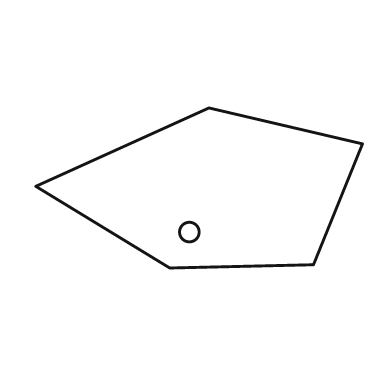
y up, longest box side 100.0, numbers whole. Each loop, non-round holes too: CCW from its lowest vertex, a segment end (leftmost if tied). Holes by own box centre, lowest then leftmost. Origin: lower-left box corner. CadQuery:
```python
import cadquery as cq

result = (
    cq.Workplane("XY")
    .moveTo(41.0, 0.0)
    .lineTo(85.0, 1.0)
    .lineTo(100.0, 38.0)
    .lineTo(53.0, 49.0)
    .lineTo(0.0, 25.0)
    .close()
    .moveTo(47.0, 11.0)
    .circle(3.0)
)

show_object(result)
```